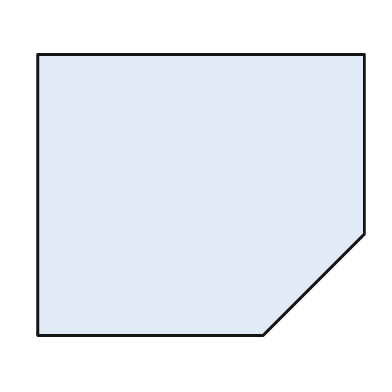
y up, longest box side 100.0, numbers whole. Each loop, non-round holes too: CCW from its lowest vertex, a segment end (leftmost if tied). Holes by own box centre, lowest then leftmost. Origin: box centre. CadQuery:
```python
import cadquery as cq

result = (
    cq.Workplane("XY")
    .moveTo(-50.0, -43.0)
    .lineTo(19.0, -43.0)
    .lineTo(50.0, -12.0)
    .lineTo(50.0, 43.0)
    .lineTo(-50.0, 43.0)
    .close()
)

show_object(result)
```